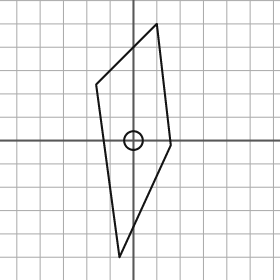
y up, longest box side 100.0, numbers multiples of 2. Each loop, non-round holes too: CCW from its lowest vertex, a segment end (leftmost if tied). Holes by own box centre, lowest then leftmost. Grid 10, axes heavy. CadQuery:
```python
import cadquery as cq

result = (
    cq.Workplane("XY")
    .moveTo(-6.0, -50.0)
    .lineTo(16.0, -2.0)
    .lineTo(10.0, 50.0)
    .lineTo(-16.0, 24.0)
    .close()
    .moveTo(0.0, 0.0)
    .circle(4.0)
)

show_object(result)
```